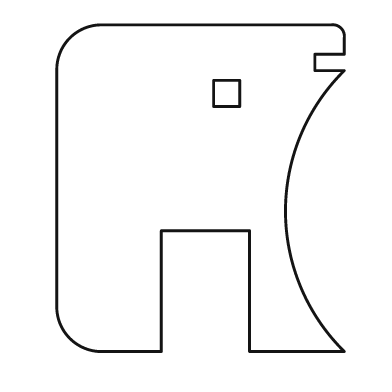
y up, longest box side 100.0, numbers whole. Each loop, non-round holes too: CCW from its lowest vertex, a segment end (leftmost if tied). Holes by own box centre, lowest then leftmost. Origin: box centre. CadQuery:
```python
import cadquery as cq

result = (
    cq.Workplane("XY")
    .moveTo(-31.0, -50.0)
    .lineTo(-12.0, -50.0)
    .lineTo(-12.0, -13.0)
    .lineTo(15.0, -13.0)
    .lineTo(15.0, -50.0)
    .lineTo(44.0, -50.0)
    .threePointArc((26.0, -7.0), (44.0, 36.0))
    .lineTo(35.0, 36.0)
    .lineTo(35.0, 41.0)
    .lineTo(44.0, 41.0)
    .lineTo(44.0, 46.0)
    .threePointArc((43.0, 49.0), (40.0, 50.0))
    .lineTo(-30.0, 50.0)
    .threePointArc((-40.0, 46.0), (-44.0, 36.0))
    .lineTo(-44.0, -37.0)
    .threePointArc((-40.0, -46.0), (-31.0, -50.0))
    .close()
    .moveTo(4.0, 25.0)
    .lineTo(12.0, 25.0)
    .lineTo(12.0, 33.0)
    .lineTo(4.0, 33.0)
    .close()
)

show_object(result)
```